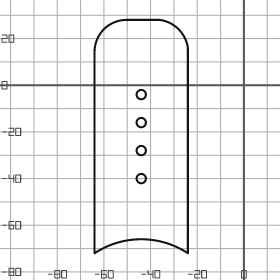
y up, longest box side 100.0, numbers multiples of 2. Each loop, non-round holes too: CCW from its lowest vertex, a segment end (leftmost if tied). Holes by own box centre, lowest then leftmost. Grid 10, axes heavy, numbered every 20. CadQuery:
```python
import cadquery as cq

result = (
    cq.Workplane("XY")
    .moveTo(-64.0, -72.0)
    .threePointArc((-44.0, -66.0), (-24.0, -72.0))
    .lineTo(-24.0, 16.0)
    .threePointArc((-28.0, 24.0), (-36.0, 28.0))
    .lineTo(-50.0, 28.0)
    .threePointArc((-60.0, 24.0), (-64.0, 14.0))
    .close()
    .moveTo(-44.0, -40.0)
    .circle(2.0)
    .moveTo(-44.0, -28.0)
    .circle(2.0)
    .moveTo(-44.0, -16.0)
    .circle(2.0)
    .moveTo(-44.0, -4.0)
    .circle(2.0)
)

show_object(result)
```